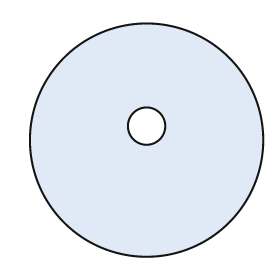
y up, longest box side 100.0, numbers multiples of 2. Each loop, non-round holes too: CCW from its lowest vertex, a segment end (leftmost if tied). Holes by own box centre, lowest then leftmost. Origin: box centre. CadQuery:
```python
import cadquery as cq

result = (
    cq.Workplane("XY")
    .moveTo(0.0, 0.0)
    .circle(50.0)
    .moveTo(0.0, 6.0)
    .circle(8.0)
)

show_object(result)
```